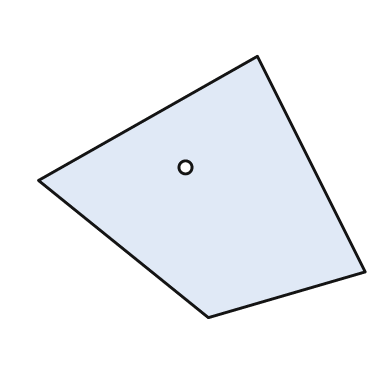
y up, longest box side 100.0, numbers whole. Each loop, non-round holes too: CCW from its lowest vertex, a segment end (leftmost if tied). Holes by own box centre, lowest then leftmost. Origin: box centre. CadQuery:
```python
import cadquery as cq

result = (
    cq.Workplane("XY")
    .moveTo(2.0, -40.0)
    .lineTo(50.0, -26.0)
    .lineTo(17.0, 40.0)
    .lineTo(-50.0, 2.0)
    .close()
    .moveTo(-5.0, 6.0)
    .circle(2.0)
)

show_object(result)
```